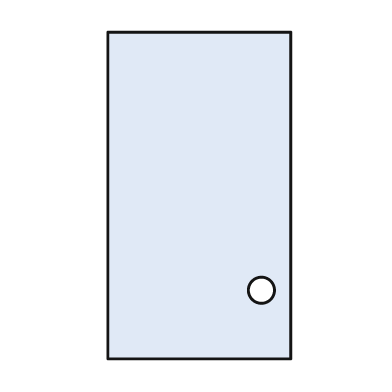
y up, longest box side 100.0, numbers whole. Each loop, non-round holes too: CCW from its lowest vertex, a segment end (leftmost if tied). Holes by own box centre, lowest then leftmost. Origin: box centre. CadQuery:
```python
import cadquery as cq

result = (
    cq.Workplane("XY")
    .moveTo(-28.0, -50.0)
    .lineTo(28.0, -50.0)
    .lineTo(28.0, 50.0)
    .lineTo(-28.0, 50.0)
    .close()
    .moveTo(19.0, -29.0)
    .circle(4.0)
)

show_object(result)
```